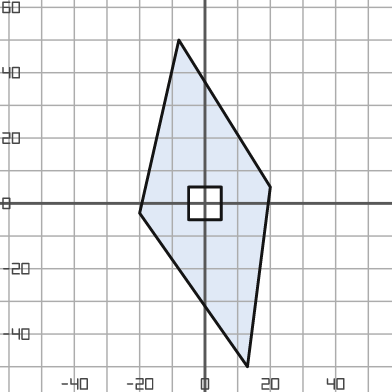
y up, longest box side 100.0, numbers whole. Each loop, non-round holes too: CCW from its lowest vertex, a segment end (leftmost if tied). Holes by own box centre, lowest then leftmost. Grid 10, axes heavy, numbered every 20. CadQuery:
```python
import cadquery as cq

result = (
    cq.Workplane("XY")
    .moveTo(13.0, -50.0)
    .lineTo(20.0, 5.0)
    .lineTo(-8.0, 50.0)
    .lineTo(-20.0, -3.0)
    .close()
    .moveTo(-5.0, -5.0)
    .lineTo(5.0, -5.0)
    .lineTo(5.0, 5.0)
    .lineTo(-5.0, 5.0)
    .close()
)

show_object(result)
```